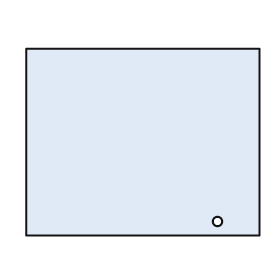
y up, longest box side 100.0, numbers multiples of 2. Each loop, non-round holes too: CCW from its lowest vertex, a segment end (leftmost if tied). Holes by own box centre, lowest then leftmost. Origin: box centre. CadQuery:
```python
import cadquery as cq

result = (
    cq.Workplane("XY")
    .moveTo(-50.0, -40.0)
    .lineTo(50.0, -40.0)
    .lineTo(50.0, 40.0)
    .lineTo(-50.0, 40.0)
    .close()
    .moveTo(32.0, -34.0)
    .circle(2.0)
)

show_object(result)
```